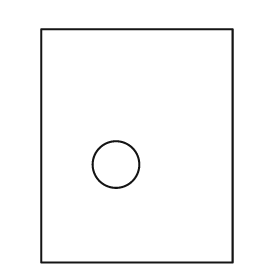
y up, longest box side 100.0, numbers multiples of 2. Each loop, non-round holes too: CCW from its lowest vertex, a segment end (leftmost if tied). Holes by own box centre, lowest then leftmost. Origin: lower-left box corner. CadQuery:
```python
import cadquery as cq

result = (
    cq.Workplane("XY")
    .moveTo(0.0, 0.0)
    .lineTo(82.0, 0.0)
    .lineTo(82.0, 100.0)
    .lineTo(0.0, 100.0)
    .close()
    .moveTo(32.0, 42.0)
    .circle(10.0)
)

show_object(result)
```